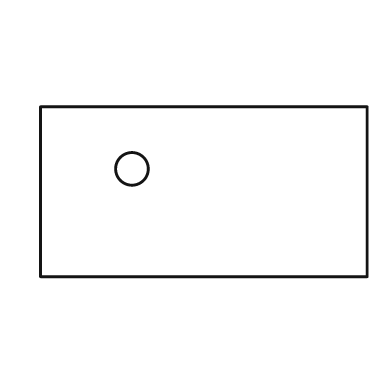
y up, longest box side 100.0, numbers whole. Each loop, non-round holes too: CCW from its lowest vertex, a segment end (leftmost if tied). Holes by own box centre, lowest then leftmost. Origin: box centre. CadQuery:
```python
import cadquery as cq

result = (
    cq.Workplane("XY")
    .moveTo(-50.0, -26.0)
    .lineTo(50.0, -26.0)
    .lineTo(50.0, 26.0)
    .lineTo(-50.0, 26.0)
    .close()
    .moveTo(-22.0, 7.0)
    .circle(5.0)
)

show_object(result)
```